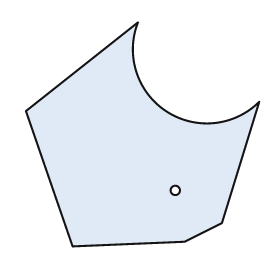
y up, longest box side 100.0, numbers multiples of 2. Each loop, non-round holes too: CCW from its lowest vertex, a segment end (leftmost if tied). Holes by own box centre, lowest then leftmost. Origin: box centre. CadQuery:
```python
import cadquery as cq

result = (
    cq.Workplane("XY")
    .moveTo(-30.0, -48.0)
    .lineTo(18.0, -46.0)
    .lineTo(34.0, -38.0)
    .lineTo(50.0, 14.0)
    .threePointArc((10.0, 10.0), (-2.0, 48.0))
    .lineTo(-50.0, 10.0)
    .close()
    .moveTo(14.0, -24.0)
    .circle(2.0)
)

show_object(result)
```